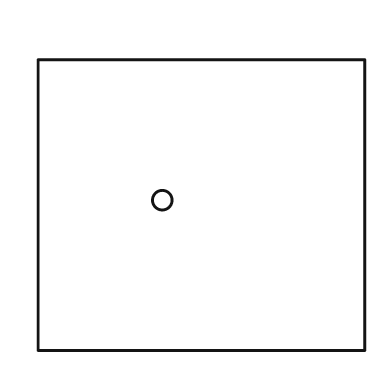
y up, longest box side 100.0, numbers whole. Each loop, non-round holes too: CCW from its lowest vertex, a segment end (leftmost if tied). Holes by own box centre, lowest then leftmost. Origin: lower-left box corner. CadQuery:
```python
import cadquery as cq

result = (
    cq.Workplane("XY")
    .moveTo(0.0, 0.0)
    .lineTo(100.0, 0.0)
    .lineTo(100.0, 89.0)
    .lineTo(0.0, 89.0)
    .close()
    .moveTo(38.0, 46.0)
    .circle(3.0)
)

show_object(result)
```